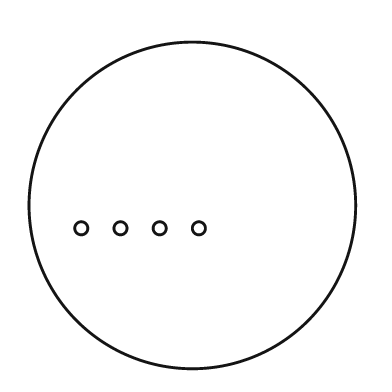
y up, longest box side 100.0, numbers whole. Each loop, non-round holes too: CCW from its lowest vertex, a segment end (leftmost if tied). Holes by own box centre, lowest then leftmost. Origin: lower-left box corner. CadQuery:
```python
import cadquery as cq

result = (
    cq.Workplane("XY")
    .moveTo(50.0, 50.0)
    .circle(50.0)
    .moveTo(16.0, 43.0)
    .circle(2.0)
    .moveTo(28.0, 43.0)
    .circle(2.0)
    .moveTo(40.0, 43.0)
    .circle(2.0)
    .moveTo(52.0, 43.0)
    .circle(2.0)
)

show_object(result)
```